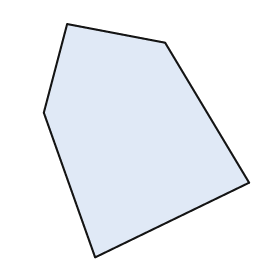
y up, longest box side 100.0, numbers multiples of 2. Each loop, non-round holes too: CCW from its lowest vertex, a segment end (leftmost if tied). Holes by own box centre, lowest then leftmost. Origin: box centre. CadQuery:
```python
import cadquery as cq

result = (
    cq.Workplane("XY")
    .moveTo(-22.0, -50.0)
    .lineTo(44.0, -18.0)
    .lineTo(8.0, 42.0)
    .lineTo(-34.0, 50.0)
    .lineTo(-44.0, 12.0)
    .close()
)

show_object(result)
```